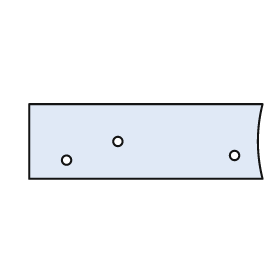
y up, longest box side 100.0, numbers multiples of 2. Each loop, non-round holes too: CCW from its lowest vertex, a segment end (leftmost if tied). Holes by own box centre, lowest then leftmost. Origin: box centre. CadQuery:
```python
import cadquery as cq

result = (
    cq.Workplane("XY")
    .moveTo(-50.0, -16.0)
    .lineTo(50.0, -16.0)
    .threePointArc((48.0, 0.0), (50.0, 16.0))
    .lineTo(-50.0, 16.0)
    .close()
    .moveTo(-34.0, -8.0)
    .circle(2.0)
    .moveTo(38.0, -6.0)
    .circle(2.0)
    .moveTo(-12.0, 0.0)
    .circle(2.0)
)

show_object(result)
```